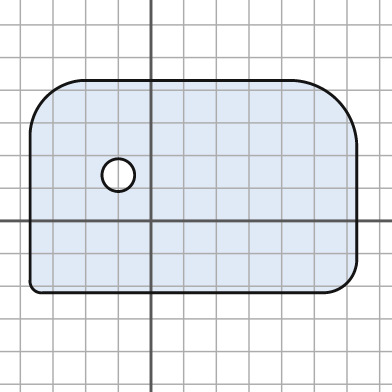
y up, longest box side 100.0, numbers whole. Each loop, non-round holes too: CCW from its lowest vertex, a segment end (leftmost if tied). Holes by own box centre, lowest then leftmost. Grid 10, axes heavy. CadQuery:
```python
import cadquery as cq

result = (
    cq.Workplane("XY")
    .moveTo(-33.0, -22.0)
    .lineTo(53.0, -22.0)
    .threePointArc((60.0, -19.0), (63.0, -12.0))
    .lineTo(63.0, 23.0)
    .threePointArc((57.0, 37.0), (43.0, 43.0))
    .lineTo(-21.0, 43.0)
    .threePointArc((-32.0, 38.0), (-37.0, 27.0))
    .lineTo(-37.0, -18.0)
    .threePointArc((-36.0, -21.0), (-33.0, -22.0))
    .close()
    .moveTo(-10.0, 14.0)
    .circle(5.0)
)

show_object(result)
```